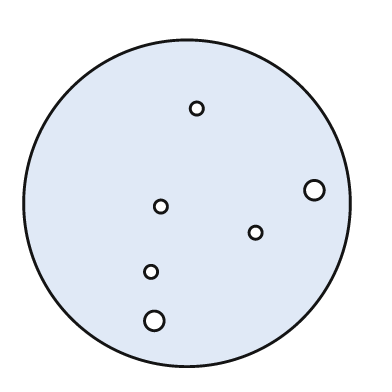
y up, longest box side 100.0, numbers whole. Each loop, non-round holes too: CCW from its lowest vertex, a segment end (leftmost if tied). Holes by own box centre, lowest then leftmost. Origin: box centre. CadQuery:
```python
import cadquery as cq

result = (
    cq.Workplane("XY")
    .moveTo(0.0, 0.0)
    .circle(50.0)
    .moveTo(-10.0, -36.0)
    .circle(3.0)
    .moveTo(-11.0, -21.0)
    .circle(2.0)
    .moveTo(21.0, -9.0)
    .circle(2.0)
    .moveTo(-8.0, -1.0)
    .circle(2.0)
    .moveTo(39.0, 4.0)
    .circle(3.0)
    .moveTo(3.0, 29.0)
    .circle(2.0)
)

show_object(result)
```